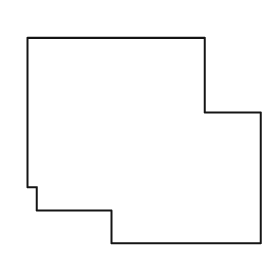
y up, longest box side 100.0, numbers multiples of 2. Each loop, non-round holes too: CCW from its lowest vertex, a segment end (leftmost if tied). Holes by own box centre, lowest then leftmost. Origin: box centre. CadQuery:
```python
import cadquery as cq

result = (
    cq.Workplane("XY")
    .moveTo(-14.0, -44.0)
    .lineTo(50.0, -44.0)
    .lineTo(50.0, 12.0)
    .lineTo(26.0, 12.0)
    .lineTo(26.0, 44.0)
    .lineTo(-50.0, 44.0)
    .lineTo(-50.0, -20.0)
    .lineTo(-46.0, -20.0)
    .lineTo(-46.0, -30.0)
    .lineTo(-14.0, -30.0)
    .close()
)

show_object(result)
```